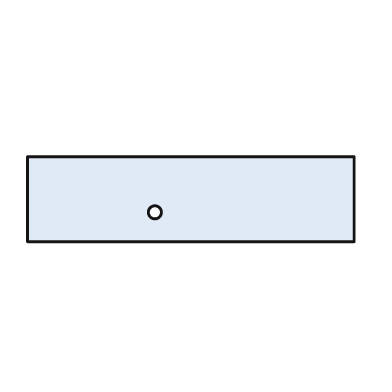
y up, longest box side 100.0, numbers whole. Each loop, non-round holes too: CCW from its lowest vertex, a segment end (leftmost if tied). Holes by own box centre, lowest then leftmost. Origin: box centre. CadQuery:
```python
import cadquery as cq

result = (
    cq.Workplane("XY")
    .moveTo(-50.0, -13.0)
    .lineTo(50.0, -13.0)
    .lineTo(50.0, 13.0)
    .lineTo(-50.0, 13.0)
    .close()
    .moveTo(-11.0, -4.0)
    .circle(2.0)
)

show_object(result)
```